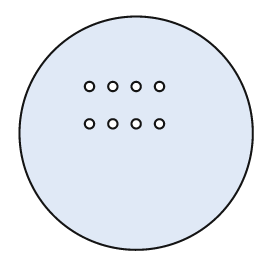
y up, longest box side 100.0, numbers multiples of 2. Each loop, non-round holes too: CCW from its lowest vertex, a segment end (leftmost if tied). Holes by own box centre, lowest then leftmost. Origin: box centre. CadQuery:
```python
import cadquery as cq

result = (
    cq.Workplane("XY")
    .moveTo(0.0, 0.0)
    .circle(50.0)
    .moveTo(-20.0, 4.0)
    .circle(2.0)
    .moveTo(-10.0, 4.0)
    .circle(2.0)
    .moveTo(0.0, 4.0)
    .circle(2.0)
    .moveTo(10.0, 4.0)
    .circle(2.0)
    .moveTo(-20.0, 20.0)
    .circle(2.0)
    .moveTo(-10.0, 20.0)
    .circle(2.0)
    .moveTo(0.0, 20.0)
    .circle(2.0)
    .moveTo(10.0, 20.0)
    .circle(2.0)
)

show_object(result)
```